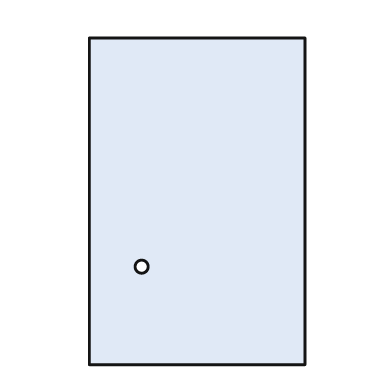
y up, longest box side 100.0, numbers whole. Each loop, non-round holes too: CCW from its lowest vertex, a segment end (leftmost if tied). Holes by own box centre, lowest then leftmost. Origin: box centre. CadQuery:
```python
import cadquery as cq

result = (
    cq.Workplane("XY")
    .moveTo(-33.0, -50.0)
    .lineTo(33.0, -50.0)
    .lineTo(33.0, 50.0)
    .lineTo(-33.0, 50.0)
    .close()
    .moveTo(-17.0, -20.0)
    .circle(2.0)
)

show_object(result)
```